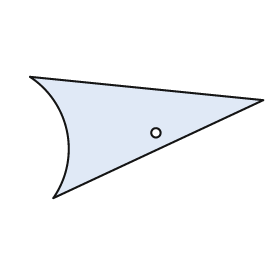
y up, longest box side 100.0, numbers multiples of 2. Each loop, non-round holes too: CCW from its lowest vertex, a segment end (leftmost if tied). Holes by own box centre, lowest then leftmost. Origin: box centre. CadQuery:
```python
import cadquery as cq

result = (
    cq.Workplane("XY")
    .moveTo(-40.0, -26.0)
    .lineTo(50.0, 16.0)
    .lineTo(-50.0, 26.0)
    .threePointArc((-34.0, 2.0), (-40.0, -26.0))
    .close()
    .moveTo(4.0, 2.0)
    .circle(2.0)
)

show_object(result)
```